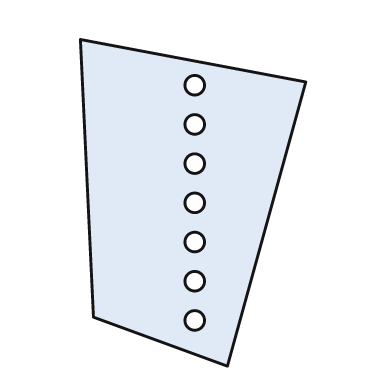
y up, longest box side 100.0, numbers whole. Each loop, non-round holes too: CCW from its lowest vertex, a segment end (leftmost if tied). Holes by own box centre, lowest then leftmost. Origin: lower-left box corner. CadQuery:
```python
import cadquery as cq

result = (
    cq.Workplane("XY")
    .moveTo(45.0, 0.0)
    .lineTo(69.0, 87.0)
    .lineTo(0.0, 100.0)
    .lineTo(4.0, 15.0)
    .close()
    .moveTo(35.0, 14.0)
    .circle(3.0)
    .moveTo(35.0, 26.0)
    .circle(3.0)
    .moveTo(35.0, 38.0)
    .circle(3.0)
    .moveTo(35.0, 50.0)
    .circle(3.0)
    .moveTo(35.0, 62.0)
    .circle(3.0)
    .moveTo(35.0, 74.0)
    .circle(3.0)
    .moveTo(35.0, 86.0)
    .circle(3.0)
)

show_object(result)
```